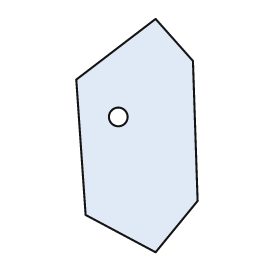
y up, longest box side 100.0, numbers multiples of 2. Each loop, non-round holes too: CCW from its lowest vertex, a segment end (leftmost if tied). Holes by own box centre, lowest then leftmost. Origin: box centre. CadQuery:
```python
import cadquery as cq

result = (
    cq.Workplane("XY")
    .moveTo(8.0, -50.0)
    .lineTo(26.0, -28.0)
    .lineTo(24.0, 32.0)
    .lineTo(8.0, 50.0)
    .lineTo(-26.0, 24.0)
    .lineTo(-22.0, -34.0)
    .close()
    .moveTo(-8.0, 8.0)
    .circle(4.0)
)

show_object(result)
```